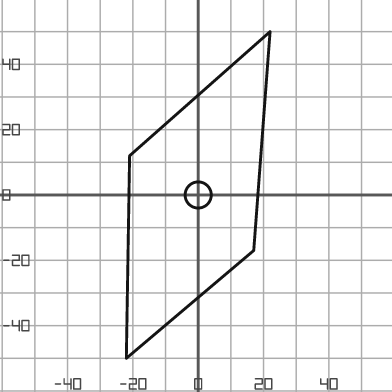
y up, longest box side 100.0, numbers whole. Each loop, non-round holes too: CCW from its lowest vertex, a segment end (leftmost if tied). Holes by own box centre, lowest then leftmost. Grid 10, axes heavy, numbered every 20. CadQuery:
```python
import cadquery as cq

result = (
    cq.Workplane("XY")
    .moveTo(-22.0, -50.0)
    .lineTo(17.0, -17.0)
    .lineTo(22.0, 50.0)
    .lineTo(-21.0, 12.0)
    .close()
    .moveTo(0.0, 0.0)
    .circle(4.0)
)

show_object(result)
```